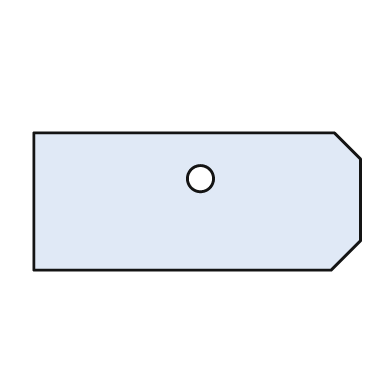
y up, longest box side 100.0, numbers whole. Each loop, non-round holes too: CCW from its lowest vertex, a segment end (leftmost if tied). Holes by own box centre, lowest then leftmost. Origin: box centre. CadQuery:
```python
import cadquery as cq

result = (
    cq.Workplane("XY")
    .moveTo(-50.0, -21.0)
    .lineTo(41.0, -21.0)
    .lineTo(50.0, -12.0)
    .lineTo(50.0, 13.0)
    .lineTo(42.0, 21.0)
    .lineTo(-50.0, 21.0)
    .close()
    .moveTo(1.0, 7.0)
    .circle(4.0)
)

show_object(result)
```